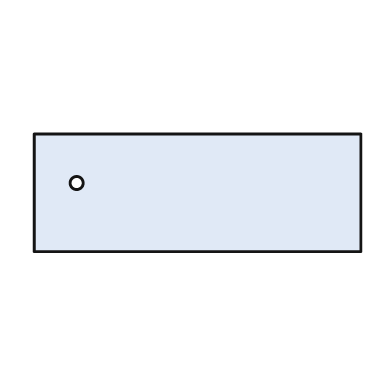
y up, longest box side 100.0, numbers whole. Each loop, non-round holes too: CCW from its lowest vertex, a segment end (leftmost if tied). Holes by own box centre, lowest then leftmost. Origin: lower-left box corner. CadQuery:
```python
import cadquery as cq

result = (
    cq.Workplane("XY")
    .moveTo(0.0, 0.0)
    .lineTo(100.0, 0.0)
    .lineTo(100.0, 36.0)
    .lineTo(0.0, 36.0)
    .close()
    .moveTo(13.0, 21.0)
    .circle(2.0)
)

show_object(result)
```